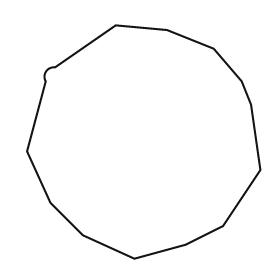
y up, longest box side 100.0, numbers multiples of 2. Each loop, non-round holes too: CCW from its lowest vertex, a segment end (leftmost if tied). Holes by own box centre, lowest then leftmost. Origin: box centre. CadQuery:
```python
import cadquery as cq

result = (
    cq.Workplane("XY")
    .moveTo(-4.0, -50.0)
    .lineTo(18.0, -44.0)
    .lineTo(34.0, -36.0)
    .lineTo(50.0, -12.0)
    .lineTo(46.0, 16.0)
    .lineTo(42.0, 26.0)
    .lineTo(30.0, 40.0)
    .lineTo(10.0, 48.0)
    .lineTo(-12.0, 50.0)
    .lineTo(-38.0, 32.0)
    .threePointArc((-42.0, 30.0), (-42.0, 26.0))
    .lineTo(-50.0, -4.0)
    .lineTo(-40.0, -26.0)
    .lineTo(-26.0, -40.0)
    .close()
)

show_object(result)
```